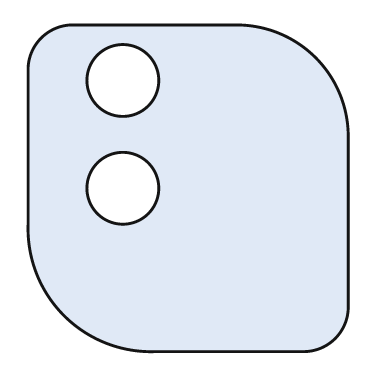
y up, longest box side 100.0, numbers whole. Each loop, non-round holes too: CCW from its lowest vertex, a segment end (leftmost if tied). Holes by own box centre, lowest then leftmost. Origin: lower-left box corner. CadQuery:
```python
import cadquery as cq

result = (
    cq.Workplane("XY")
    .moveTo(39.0, 0.0)
    .lineTo(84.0, 0.0)
    .threePointArc((94.0, 4.0), (98.0, 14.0))
    .lineTo(98.0, 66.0)
    .threePointArc((88.0, 90.0), (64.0, 100.0))
    .lineTo(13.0, 100.0)
    .threePointArc((4.0, 96.0), (0.0, 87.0))
    .lineTo(0.0, 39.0)
    .threePointArc((11.0, 11.0), (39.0, 0.0))
    .close()
    .moveTo(29.0, 50.0)
    .circle(11.0)
    .moveTo(29.0, 83.0)
    .circle(11.0)
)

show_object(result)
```